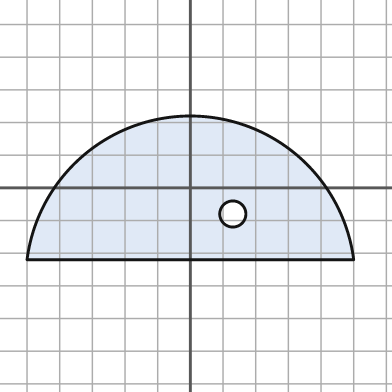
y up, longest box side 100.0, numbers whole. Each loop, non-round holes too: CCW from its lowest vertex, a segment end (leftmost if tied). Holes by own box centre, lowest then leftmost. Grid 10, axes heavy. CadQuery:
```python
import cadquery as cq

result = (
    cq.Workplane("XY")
    .moveTo(-50.0, -22.0)
    .lineTo(50.0, -22.0)
    .threePointArc((0.0, 22.0), (-50.0, -22.0))
    .close()
    .moveTo(13.0, -8.0)
    .circle(4.0)
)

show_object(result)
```